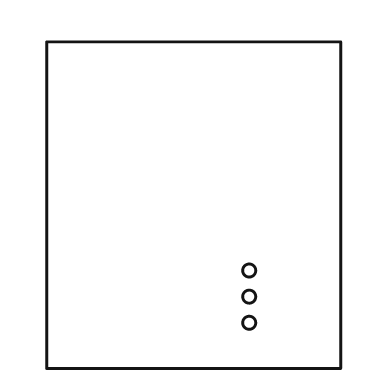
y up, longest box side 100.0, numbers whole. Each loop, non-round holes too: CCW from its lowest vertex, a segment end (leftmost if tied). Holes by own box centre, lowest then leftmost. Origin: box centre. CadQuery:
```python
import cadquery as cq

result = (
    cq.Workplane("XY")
    .moveTo(-45.0, -50.0)
    .lineTo(45.0, -50.0)
    .lineTo(45.0, 50.0)
    .lineTo(-45.0, 50.0)
    .close()
    .moveTo(17.0, -36.0)
    .circle(2.0)
    .moveTo(17.0, -28.0)
    .circle(2.0)
    .moveTo(17.0, -20.0)
    .circle(2.0)
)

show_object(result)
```